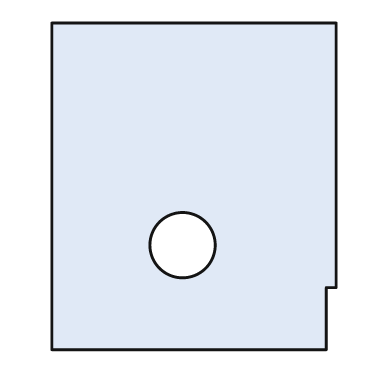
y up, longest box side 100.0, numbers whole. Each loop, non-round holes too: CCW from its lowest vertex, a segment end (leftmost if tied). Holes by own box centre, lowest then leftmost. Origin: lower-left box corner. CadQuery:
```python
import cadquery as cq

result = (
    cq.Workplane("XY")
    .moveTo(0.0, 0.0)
    .lineTo(84.0, 0.0)
    .lineTo(84.0, 19.0)
    .lineTo(87.0, 19.0)
    .lineTo(87.0, 100.0)
    .lineTo(0.0, 100.0)
    .close()
    .moveTo(40.0, 32.0)
    .circle(10.0)
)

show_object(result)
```